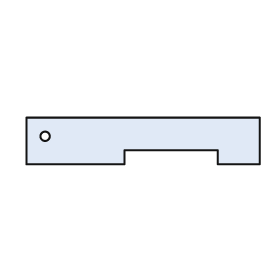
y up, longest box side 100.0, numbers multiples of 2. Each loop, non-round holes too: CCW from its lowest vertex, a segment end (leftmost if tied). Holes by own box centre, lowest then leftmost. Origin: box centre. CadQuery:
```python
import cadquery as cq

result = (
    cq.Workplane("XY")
    .moveTo(-50.0, -10.0)
    .lineTo(-8.0, -10.0)
    .lineTo(-8.0, -4.0)
    .lineTo(32.0, -4.0)
    .lineTo(32.0, -10.0)
    .lineTo(50.0, -10.0)
    .lineTo(50.0, 10.0)
    .lineTo(-50.0, 10.0)
    .close()
    .moveTo(-42.0, 2.0)
    .circle(2.0)
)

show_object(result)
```